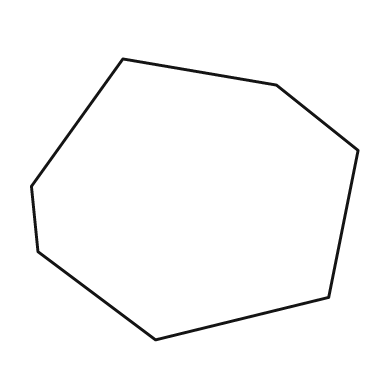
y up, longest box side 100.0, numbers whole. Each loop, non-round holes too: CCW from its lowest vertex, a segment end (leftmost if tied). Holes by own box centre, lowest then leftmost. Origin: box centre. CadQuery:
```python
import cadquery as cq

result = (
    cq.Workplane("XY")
    .moveTo(-12.0, -43.0)
    .lineTo(41.0, -30.0)
    .lineTo(50.0, 15.0)
    .lineTo(25.0, 35.0)
    .lineTo(-22.0, 43.0)
    .lineTo(-50.0, 4.0)
    .lineTo(-48.0, -16.0)
    .close()
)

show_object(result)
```